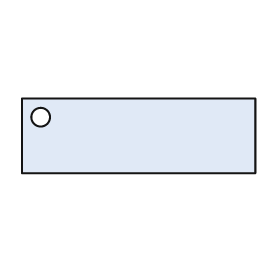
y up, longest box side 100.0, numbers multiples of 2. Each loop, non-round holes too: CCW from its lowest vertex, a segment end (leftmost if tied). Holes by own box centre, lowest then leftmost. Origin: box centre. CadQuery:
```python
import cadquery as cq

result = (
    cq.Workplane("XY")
    .moveTo(-50.0, -16.0)
    .lineTo(50.0, -16.0)
    .lineTo(50.0, 16.0)
    .lineTo(-50.0, 16.0)
    .close()
    .moveTo(-42.0, 8.0)
    .circle(4.0)
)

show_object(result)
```